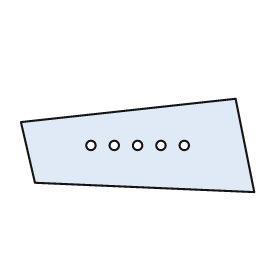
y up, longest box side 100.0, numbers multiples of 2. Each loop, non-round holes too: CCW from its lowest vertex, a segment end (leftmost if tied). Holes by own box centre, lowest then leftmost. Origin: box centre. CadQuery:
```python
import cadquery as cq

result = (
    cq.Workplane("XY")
    .moveTo(50.0, -20.0)
    .lineTo(42.0, 20.0)
    .lineTo(-50.0, 10.0)
    .lineTo(-44.0, -16.0)
    .close()
    .moveTo(-20.0, 0.0)
    .circle(2.0)
    .moveTo(-10.0, 0.0)
    .circle(2.0)
    .moveTo(0.0, 0.0)
    .circle(2.0)
    .moveTo(10.0, 0.0)
    .circle(2.0)
    .moveTo(20.0, 0.0)
    .circle(2.0)
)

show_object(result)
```